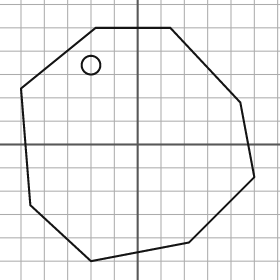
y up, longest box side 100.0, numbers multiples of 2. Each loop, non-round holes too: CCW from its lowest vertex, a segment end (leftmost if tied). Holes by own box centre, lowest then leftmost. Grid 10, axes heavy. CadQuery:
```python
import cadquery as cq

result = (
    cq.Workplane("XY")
    .moveTo(-20.0, -50.0)
    .lineTo(22.0, -42.0)
    .lineTo(50.0, -14.0)
    .lineTo(44.0, 18.0)
    .lineTo(14.0, 50.0)
    .lineTo(-18.0, 50.0)
    .lineTo(-50.0, 24.0)
    .lineTo(-46.0, -26.0)
    .close()
    .moveTo(-20.0, 34.0)
    .circle(4.0)
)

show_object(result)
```